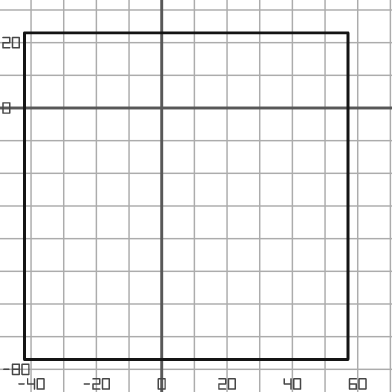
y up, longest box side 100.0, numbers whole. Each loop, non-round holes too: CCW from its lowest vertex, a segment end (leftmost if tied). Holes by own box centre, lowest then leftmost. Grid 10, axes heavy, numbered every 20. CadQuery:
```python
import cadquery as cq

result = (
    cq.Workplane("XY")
    .moveTo(-42.0, -77.0)
    .lineTo(57.0, -77.0)
    .lineTo(57.0, 23.0)
    .lineTo(-42.0, 23.0)
    .close()
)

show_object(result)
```